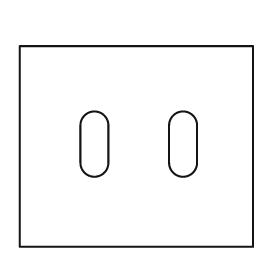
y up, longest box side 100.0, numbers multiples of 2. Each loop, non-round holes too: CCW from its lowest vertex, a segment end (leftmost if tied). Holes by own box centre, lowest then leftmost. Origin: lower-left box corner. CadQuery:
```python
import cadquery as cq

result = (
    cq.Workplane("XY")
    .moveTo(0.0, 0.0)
    .lineTo(100.0, 0.0)
    .lineTo(100.0, 86.0)
    .lineTo(0.0, 86.0)
    .close()
    .moveTo(26.0, 36.0)
    .threePointArc((32.0, 30.0), (38.0, 36.0))
    .lineTo(38.0, 52.0)
    .threePointArc((32.0, 58.0), (26.0, 52.0))
    .close()
    .moveTo(64.0, 36.0)
    .threePointArc((70.0, 30.0), (76.0, 36.0))
    .lineTo(76.0, 52.0)
    .threePointArc((70.0, 58.0), (64.0, 52.0))
    .close()
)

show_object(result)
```